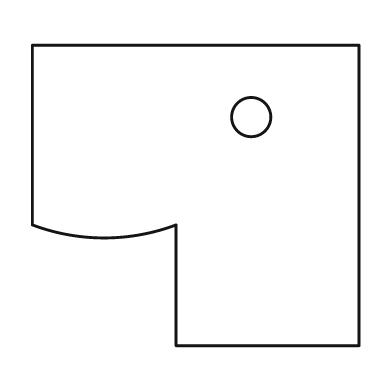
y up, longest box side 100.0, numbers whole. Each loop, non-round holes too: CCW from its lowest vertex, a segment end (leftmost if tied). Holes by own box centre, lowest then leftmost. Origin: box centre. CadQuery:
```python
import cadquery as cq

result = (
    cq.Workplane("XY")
    .moveTo(-6.0, -46.0)
    .lineTo(50.0, -46.0)
    .lineTo(50.0, 46.0)
    .lineTo(-50.0, 46.0)
    .lineTo(-50.0, -9.0)
    .threePointArc((-28.0, -13.0), (-6.0, -9.0))
    .close()
    .moveTo(17.0, 24.0)
    .circle(6.0)
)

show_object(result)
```